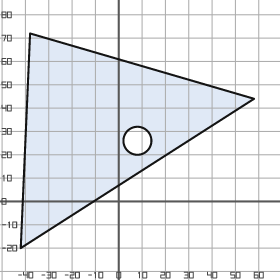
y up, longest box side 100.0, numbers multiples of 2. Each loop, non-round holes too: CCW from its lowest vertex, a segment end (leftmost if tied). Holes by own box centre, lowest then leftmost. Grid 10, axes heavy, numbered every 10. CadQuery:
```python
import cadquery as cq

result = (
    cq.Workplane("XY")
    .moveTo(-42.0, -20.0)
    .lineTo(58.0, 44.0)
    .lineTo(-38.0, 72.0)
    .close()
    .moveTo(8.0, 26.0)
    .circle(6.0)
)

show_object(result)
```